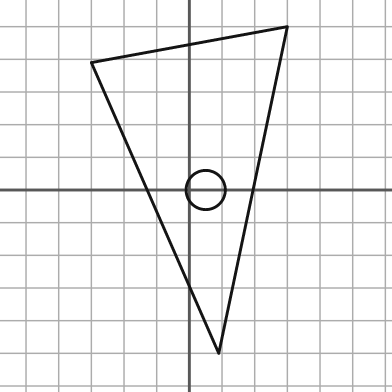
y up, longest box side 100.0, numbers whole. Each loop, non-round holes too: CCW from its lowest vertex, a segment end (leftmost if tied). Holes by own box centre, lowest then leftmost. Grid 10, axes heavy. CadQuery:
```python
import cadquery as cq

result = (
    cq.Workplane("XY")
    .moveTo(9.0, -50.0)
    .lineTo(30.0, 50.0)
    .lineTo(-30.0, 39.0)
    .close()
    .moveTo(5.0, 0.0)
    .circle(6.0)
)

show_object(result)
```